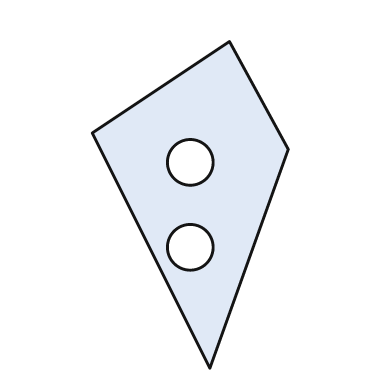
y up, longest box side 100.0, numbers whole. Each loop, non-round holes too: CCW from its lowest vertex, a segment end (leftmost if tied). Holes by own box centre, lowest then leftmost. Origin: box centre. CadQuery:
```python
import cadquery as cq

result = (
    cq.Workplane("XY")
    .moveTo(6.0, -50.0)
    .lineTo(30.0, 17.0)
    .lineTo(12.0, 50.0)
    .lineTo(-30.0, 22.0)
    .close()
    .moveTo(0.0, -13.0)
    .circle(7.0)
    .moveTo(0.0, 13.0)
    .circle(7.0)
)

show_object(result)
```